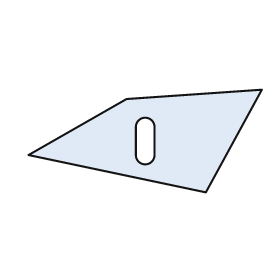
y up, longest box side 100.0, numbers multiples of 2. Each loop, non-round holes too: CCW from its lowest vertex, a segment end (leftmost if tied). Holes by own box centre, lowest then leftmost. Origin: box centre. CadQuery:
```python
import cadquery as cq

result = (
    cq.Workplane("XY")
    .moveTo(26.0, -22.0)
    .lineTo(50.0, 22.0)
    .lineTo(-8.0, 18.0)
    .lineTo(-50.0, -6.0)
    .close()
    .moveTo(-4.0, -6.0)
    .threePointArc((0.0, -10.0), (4.0, -6.0))
    .lineTo(4.0, 6.0)
    .threePointArc((0.0, 10.0), (-4.0, 6.0))
    .close()
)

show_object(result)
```